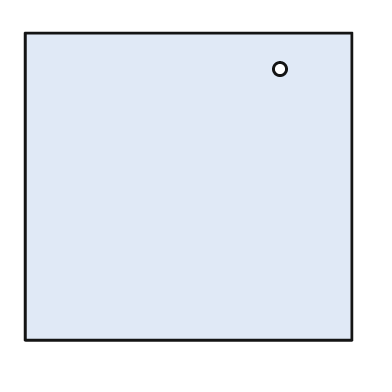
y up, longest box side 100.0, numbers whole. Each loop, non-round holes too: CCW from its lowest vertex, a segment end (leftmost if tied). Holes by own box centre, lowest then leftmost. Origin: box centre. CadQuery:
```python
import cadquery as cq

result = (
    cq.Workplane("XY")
    .moveTo(-50.0, -47.0)
    .lineTo(50.0, -47.0)
    .lineTo(50.0, 47.0)
    .lineTo(-50.0, 47.0)
    .close()
    .moveTo(28.0, 36.0)
    .circle(2.0)
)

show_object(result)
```